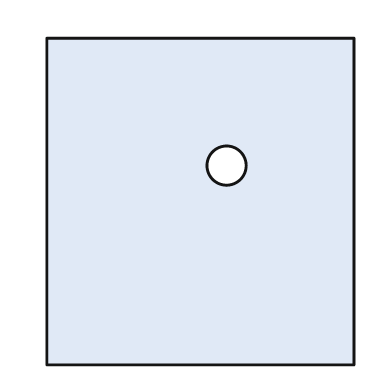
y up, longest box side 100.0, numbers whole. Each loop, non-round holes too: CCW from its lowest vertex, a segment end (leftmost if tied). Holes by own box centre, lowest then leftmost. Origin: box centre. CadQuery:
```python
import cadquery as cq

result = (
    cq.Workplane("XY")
    .moveTo(-47.0, -50.0)
    .lineTo(47.0, -50.0)
    .lineTo(47.0, 50.0)
    .lineTo(-47.0, 50.0)
    .close()
    .moveTo(8.0, 11.0)
    .circle(6.0)
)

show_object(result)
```